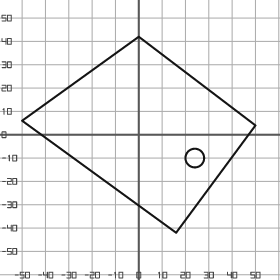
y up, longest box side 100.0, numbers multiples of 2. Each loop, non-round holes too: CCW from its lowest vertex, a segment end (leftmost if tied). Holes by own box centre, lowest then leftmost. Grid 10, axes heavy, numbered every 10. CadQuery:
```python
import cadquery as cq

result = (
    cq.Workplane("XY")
    .moveTo(16.0, -42.0)
    .lineTo(50.0, 4.0)
    .lineTo(0.0, 42.0)
    .lineTo(-50.0, 6.0)
    .close()
    .moveTo(24.0, -10.0)
    .circle(4.0)
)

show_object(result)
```